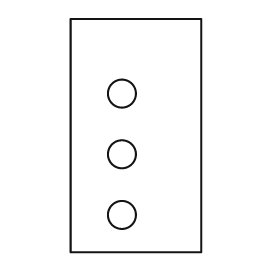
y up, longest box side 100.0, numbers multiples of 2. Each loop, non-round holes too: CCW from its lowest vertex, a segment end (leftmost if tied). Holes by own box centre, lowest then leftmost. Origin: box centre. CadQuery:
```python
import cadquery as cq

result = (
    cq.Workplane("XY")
    .moveTo(-28.0, -50.0)
    .lineTo(28.0, -50.0)
    .lineTo(28.0, 50.0)
    .lineTo(-28.0, 50.0)
    .close()
    .moveTo(-6.0, -34.0)
    .circle(6.0)
    .moveTo(-6.0, -8.0)
    .circle(6.0)
    .moveTo(-6.0, 18.0)
    .circle(6.0)
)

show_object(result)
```